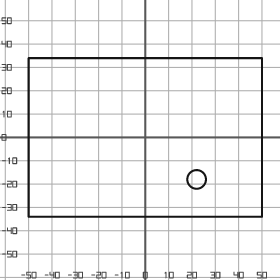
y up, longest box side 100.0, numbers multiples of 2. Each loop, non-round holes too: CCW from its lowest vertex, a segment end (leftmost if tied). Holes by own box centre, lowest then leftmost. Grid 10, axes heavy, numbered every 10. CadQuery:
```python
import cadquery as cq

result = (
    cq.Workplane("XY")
    .moveTo(-50.0, -34.0)
    .lineTo(50.0, -34.0)
    .lineTo(50.0, 34.0)
    .lineTo(-50.0, 34.0)
    .close()
    .moveTo(22.0, -18.0)
    .circle(4.0)
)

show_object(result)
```